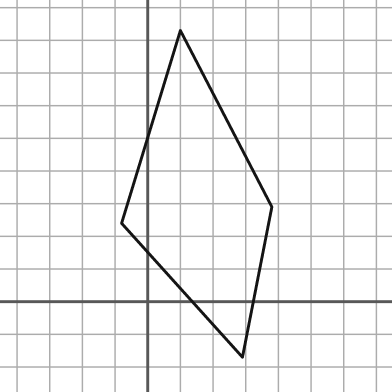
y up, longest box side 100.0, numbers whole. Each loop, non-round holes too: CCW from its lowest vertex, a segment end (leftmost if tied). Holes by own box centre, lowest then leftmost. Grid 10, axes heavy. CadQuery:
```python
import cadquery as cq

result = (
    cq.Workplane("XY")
    .moveTo(29.0, -17.0)
    .lineTo(38.0, 29.0)
    .lineTo(10.0, 83.0)
    .lineTo(-8.0, 24.0)
    .close()
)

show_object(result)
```